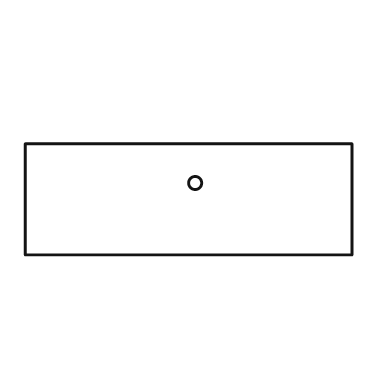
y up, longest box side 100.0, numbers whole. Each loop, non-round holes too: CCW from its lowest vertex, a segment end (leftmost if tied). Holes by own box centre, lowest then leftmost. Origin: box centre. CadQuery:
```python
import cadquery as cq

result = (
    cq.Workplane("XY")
    .moveTo(-50.0, -17.0)
    .lineTo(50.0, -17.0)
    .lineTo(50.0, 17.0)
    .lineTo(-50.0, 17.0)
    .close()
    .moveTo(2.0, 5.0)
    .circle(2.0)
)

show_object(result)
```